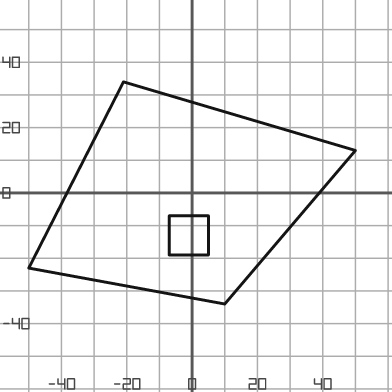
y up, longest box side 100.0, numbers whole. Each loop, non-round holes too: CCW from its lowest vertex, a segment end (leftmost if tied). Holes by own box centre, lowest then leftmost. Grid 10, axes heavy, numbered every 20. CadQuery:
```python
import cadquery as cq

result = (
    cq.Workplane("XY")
    .moveTo(10.0, -34.0)
    .lineTo(50.0, 13.0)
    .lineTo(-21.0, 34.0)
    .lineTo(-50.0, -23.0)
    .close()
    .moveTo(-7.0, -19.0)
    .lineTo(5.0, -19.0)
    .lineTo(5.0, -7.0)
    .lineTo(-7.0, -7.0)
    .close()
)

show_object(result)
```